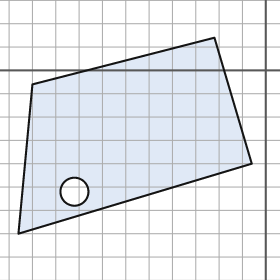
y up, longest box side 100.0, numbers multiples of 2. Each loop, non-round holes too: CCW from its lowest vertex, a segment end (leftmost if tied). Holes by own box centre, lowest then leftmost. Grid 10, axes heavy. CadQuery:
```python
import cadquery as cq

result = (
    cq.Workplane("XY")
    .moveTo(-106.0, -70.0)
    .lineTo(-6.0, -40.0)
    .lineTo(-22.0, 14.0)
    .lineTo(-100.0, -6.0)
    .close()
    .moveTo(-82.0, -52.0)
    .circle(6.0)
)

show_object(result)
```